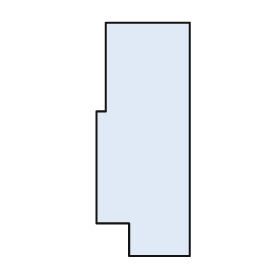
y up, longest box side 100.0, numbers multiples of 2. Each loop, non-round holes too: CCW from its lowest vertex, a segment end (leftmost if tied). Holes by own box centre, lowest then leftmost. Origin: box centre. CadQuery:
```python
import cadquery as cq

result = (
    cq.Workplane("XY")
    .moveTo(-6.0, -50.0)
    .lineTo(20.0, -50.0)
    .lineTo(20.0, 50.0)
    .lineTo(-16.0, 50.0)
    .lineTo(-16.0, 12.0)
    .lineTo(-20.0, 12.0)
    .lineTo(-20.0, -36.0)
    .lineTo(-6.0, -36.0)
    .close()
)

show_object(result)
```